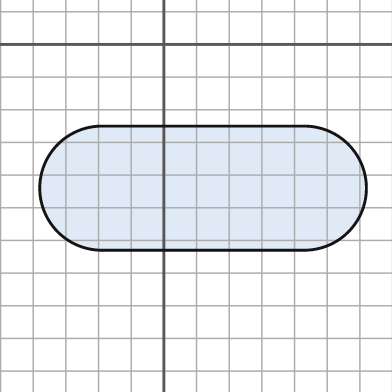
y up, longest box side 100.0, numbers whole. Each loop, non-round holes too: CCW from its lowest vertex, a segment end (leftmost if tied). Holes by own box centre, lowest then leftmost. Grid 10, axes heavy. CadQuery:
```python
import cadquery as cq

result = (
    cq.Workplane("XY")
    .moveTo(-19.0, -63.0)
    .lineTo(43.0, -63.0)
    .threePointArc((62.0, -44.0), (43.0, -25.0))
    .lineTo(-19.0, -25.0)
    .threePointArc((-38.0, -44.0), (-19.0, -63.0))
    .close()
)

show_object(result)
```